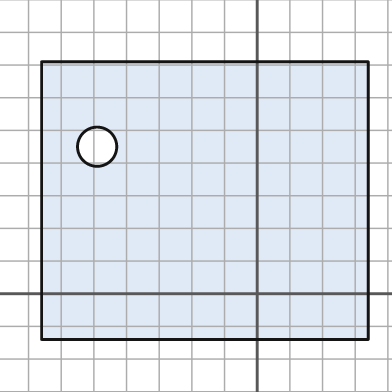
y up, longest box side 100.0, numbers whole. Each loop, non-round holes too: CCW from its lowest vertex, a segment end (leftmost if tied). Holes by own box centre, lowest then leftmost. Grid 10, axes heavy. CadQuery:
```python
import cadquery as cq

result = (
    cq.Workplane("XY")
    .moveTo(-66.0, -14.0)
    .lineTo(34.0, -14.0)
    .lineTo(34.0, 71.0)
    .lineTo(-66.0, 71.0)
    .close()
    .moveTo(-49.0, 45.0)
    .circle(6.0)
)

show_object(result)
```